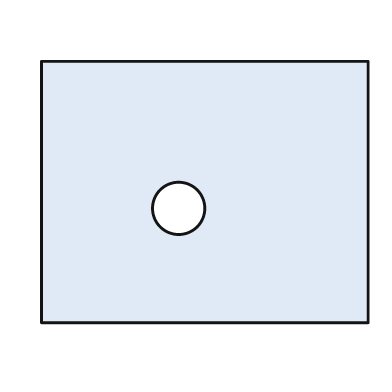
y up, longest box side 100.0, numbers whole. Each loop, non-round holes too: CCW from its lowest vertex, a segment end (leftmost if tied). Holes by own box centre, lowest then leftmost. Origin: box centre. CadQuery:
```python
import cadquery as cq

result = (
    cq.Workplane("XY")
    .moveTo(-50.0, -40.0)
    .lineTo(50.0, -40.0)
    .lineTo(50.0, 40.0)
    .lineTo(-50.0, 40.0)
    .close()
    .moveTo(-8.0, -5.0)
    .circle(8.0)
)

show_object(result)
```